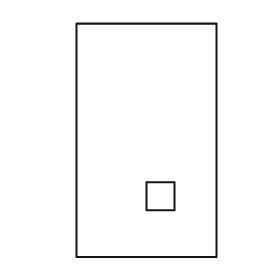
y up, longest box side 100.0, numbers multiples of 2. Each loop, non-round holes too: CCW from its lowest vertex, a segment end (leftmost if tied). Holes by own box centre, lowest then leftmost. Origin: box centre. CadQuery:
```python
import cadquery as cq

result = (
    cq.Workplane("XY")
    .moveTo(-30.0, -50.0)
    .lineTo(30.0, -50.0)
    .lineTo(30.0, 50.0)
    .lineTo(-30.0, 50.0)
    .close()
    .moveTo(0.0, -30.0)
    .lineTo(12.0, -30.0)
    .lineTo(12.0, -18.0)
    .lineTo(0.0, -18.0)
    .close()
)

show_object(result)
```